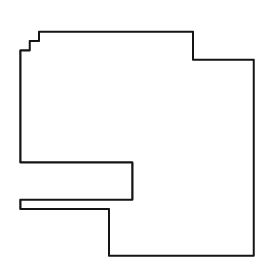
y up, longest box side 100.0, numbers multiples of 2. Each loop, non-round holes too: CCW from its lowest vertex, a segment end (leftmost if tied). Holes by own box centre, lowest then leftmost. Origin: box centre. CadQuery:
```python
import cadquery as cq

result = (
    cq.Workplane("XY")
    .moveTo(-12.0, -48.0)
    .lineTo(50.0, -48.0)
    .lineTo(50.0, 36.0)
    .lineTo(24.0, 36.0)
    .lineTo(24.0, 48.0)
    .lineTo(-42.0, 48.0)
    .lineTo(-42.0, 44.0)
    .lineTo(-46.0, 44.0)
    .lineTo(-46.0, 40.0)
    .lineTo(-50.0, 40.0)
    .lineTo(-50.0, -8.0)
    .lineTo(-2.0, -8.0)
    .lineTo(-2.0, -24.0)
    .lineTo(-50.0, -24.0)
    .lineTo(-50.0, -28.0)
    .lineTo(-12.0, -28.0)
    .close()
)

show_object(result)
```